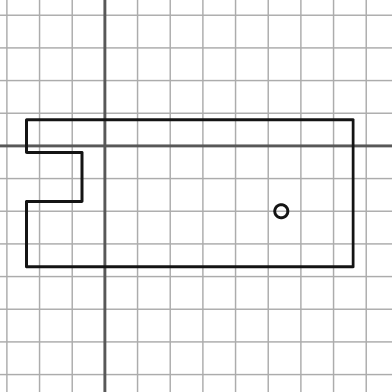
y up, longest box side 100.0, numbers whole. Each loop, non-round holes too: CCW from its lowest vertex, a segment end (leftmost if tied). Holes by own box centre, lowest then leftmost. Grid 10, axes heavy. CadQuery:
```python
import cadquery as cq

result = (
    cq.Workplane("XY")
    .moveTo(-24.0, -37.0)
    .lineTo(76.0, -37.0)
    .lineTo(76.0, 8.0)
    .lineTo(-24.0, 8.0)
    .lineTo(-24.0, -2.0)
    .lineTo(-7.0, -2.0)
    .lineTo(-7.0, -17.0)
    .lineTo(-24.0, -17.0)
    .close()
    .moveTo(54.0, -20.0)
    .circle(2.0)
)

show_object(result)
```